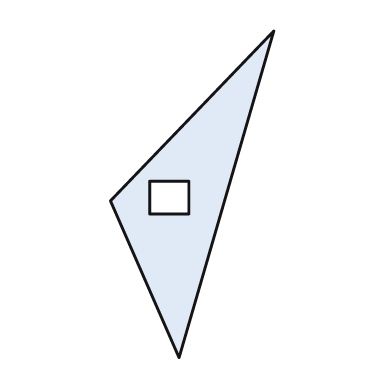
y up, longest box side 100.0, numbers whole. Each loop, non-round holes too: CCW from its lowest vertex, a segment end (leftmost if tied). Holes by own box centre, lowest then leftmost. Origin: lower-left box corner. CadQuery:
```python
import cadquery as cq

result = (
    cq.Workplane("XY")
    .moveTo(21.0, 0.0)
    .lineTo(50.0, 100.0)
    .lineTo(0.0, 48.0)
    .close()
    .moveTo(12.0, 44.0)
    .lineTo(24.0, 44.0)
    .lineTo(24.0, 54.0)
    .lineTo(12.0, 54.0)
    .close()
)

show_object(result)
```